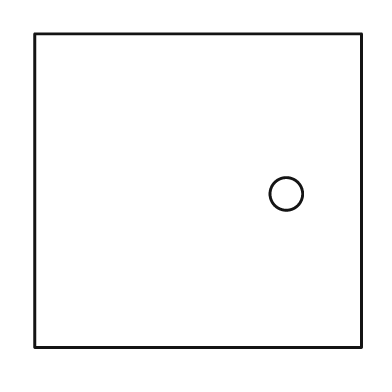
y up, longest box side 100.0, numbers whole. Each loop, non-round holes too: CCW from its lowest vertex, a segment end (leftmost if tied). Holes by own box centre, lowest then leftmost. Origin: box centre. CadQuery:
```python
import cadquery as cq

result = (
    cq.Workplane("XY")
    .moveTo(-50.0, -48.0)
    .lineTo(50.0, -48.0)
    .lineTo(50.0, 48.0)
    .lineTo(-50.0, 48.0)
    .close()
    .moveTo(27.0, -1.0)
    .circle(5.0)
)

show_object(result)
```